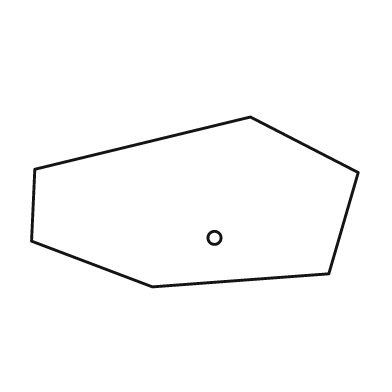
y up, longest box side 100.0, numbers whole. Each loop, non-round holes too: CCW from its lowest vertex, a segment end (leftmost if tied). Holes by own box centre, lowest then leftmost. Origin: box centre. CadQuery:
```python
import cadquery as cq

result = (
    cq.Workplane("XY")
    .moveTo(-13.0, -26.0)
    .lineTo(41.0, -22.0)
    .lineTo(50.0, 9.0)
    .lineTo(17.0, 26.0)
    .lineTo(-49.0, 10.0)
    .lineTo(-50.0, -12.0)
    .close()
    .moveTo(6.0, -11.0)
    .circle(2.0)
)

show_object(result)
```